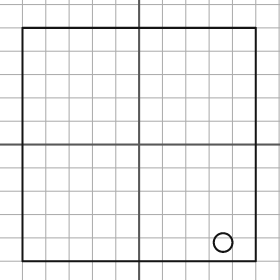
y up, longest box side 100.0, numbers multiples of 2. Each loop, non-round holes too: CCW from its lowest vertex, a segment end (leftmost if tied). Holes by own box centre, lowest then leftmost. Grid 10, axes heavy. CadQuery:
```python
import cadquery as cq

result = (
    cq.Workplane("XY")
    .moveTo(-50.0, -50.0)
    .lineTo(50.0, -50.0)
    .lineTo(50.0, 50.0)
    .lineTo(-50.0, 50.0)
    .close()
    .moveTo(36.0, -42.0)
    .circle(4.0)
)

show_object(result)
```